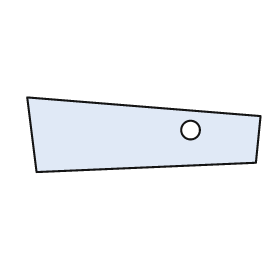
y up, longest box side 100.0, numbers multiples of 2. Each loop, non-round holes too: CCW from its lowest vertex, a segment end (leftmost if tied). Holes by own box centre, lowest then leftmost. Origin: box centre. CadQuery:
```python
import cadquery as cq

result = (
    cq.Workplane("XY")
    .moveTo(-46.0, -16.0)
    .lineTo(48.0, -12.0)
    .lineTo(50.0, 8.0)
    .lineTo(-50.0, 16.0)
    .close()
    .moveTo(20.0, 2.0)
    .circle(4.0)
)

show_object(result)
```